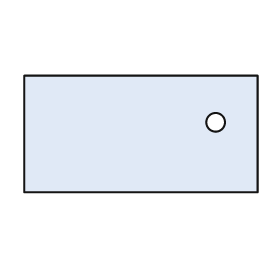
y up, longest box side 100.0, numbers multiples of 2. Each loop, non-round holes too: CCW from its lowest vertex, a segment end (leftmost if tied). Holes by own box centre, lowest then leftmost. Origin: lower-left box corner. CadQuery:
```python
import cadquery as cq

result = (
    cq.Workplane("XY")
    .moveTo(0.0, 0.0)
    .lineTo(100.0, 0.0)
    .lineTo(100.0, 50.0)
    .lineTo(0.0, 50.0)
    .close()
    .moveTo(82.0, 30.0)
    .circle(4.0)
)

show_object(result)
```